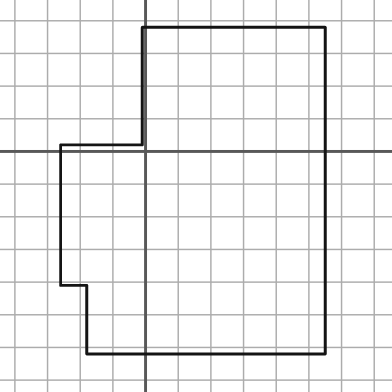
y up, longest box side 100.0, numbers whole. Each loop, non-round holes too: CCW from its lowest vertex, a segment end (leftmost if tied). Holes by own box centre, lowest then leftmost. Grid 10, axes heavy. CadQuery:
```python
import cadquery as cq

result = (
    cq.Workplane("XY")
    .moveTo(-18.0, -62.0)
    .lineTo(55.0, -62.0)
    .lineTo(55.0, 38.0)
    .lineTo(-1.0, 38.0)
    .lineTo(-1.0, 2.0)
    .lineTo(-26.0, 2.0)
    .lineTo(-26.0, -41.0)
    .lineTo(-18.0, -41.0)
    .close()
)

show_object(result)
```